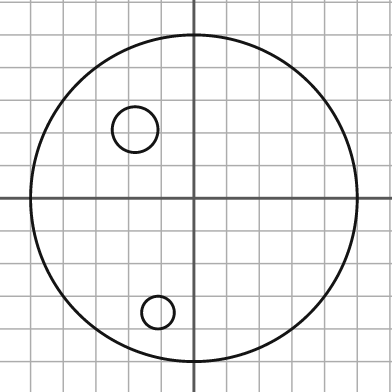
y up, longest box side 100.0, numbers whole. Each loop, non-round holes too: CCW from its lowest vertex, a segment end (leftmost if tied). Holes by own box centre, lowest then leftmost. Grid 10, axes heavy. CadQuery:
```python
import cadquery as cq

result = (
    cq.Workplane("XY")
    .moveTo(0.0, 0.0)
    .circle(50.0)
    .moveTo(-11.0, -35.0)
    .circle(5.0)
    .moveTo(-18.0, 21.0)
    .circle(7.0)
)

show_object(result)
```